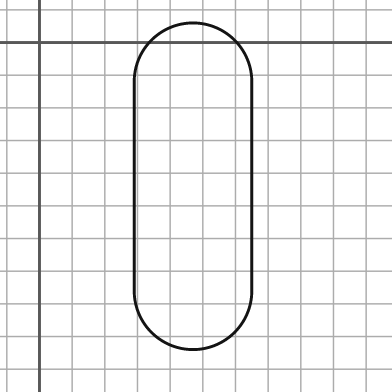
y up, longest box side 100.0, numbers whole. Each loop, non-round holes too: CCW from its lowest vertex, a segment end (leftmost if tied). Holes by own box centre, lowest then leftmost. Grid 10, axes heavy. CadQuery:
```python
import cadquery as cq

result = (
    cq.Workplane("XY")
    .moveTo(29.0, -76.0)
    .threePointArc((47.0, -94.0), (65.0, -76.0))
    .lineTo(65.0, -12.0)
    .threePointArc((47.0, 6.0), (29.0, -12.0))
    .close()
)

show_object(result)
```